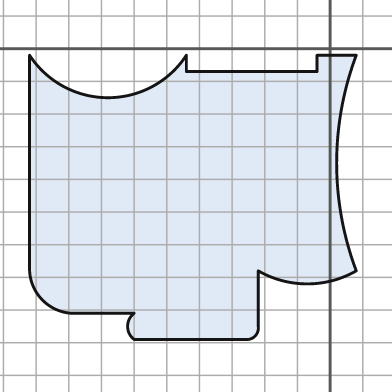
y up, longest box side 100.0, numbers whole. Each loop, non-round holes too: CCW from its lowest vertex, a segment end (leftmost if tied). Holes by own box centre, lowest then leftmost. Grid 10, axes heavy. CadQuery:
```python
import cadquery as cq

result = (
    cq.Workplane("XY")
    .moveTo(-60.0, -89.0)
    .lineTo(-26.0, -89.0)
    .threePointArc((-23.0, -88.0), (-22.0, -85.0))
    .lineTo(-22.0, -68.0)
    .threePointArc((-7.0, -72.0), (8.0, -68.0))
    .threePointArc((2.0, -35.0), (8.0, -2.0))
    .lineTo(-4.0, -2.0)
    .lineTo(-4.0, -7.0)
    .lineTo(-44.0, -7.0)
    .lineTo(-44.0, -2.0)
    .threePointArc((-68.0, -15.0), (-92.0, -2.0))
    .lineTo(-92.0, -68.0)
    .threePointArc((-88.0, -77.0), (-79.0, -81.0))
    .lineTo(-60.0, -81.0)
    .threePointArc((-62.0, -85.0), (-60.0, -89.0))
    .close()
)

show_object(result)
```